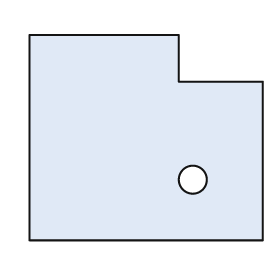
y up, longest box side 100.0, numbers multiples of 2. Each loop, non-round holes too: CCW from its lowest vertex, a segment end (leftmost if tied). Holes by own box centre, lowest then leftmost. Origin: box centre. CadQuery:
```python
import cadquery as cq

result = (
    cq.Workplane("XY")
    .moveTo(-50.0, -44.0)
    .lineTo(50.0, -44.0)
    .lineTo(50.0, 24.0)
    .lineTo(14.0, 24.0)
    .lineTo(14.0, 44.0)
    .lineTo(-50.0, 44.0)
    .close()
    .moveTo(20.0, -18.0)
    .circle(6.0)
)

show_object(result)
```